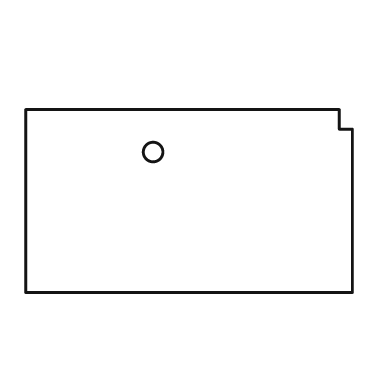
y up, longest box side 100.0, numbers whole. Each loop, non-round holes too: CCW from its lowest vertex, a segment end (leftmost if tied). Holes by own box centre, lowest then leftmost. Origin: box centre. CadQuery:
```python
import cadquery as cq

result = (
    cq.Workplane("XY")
    .moveTo(-50.0, -28.0)
    .lineTo(50.0, -28.0)
    .lineTo(50.0, 22.0)
    .lineTo(46.0, 22.0)
    .lineTo(46.0, 28.0)
    .lineTo(-50.0, 28.0)
    .close()
    .moveTo(-11.0, 15.0)
    .circle(3.0)
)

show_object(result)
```